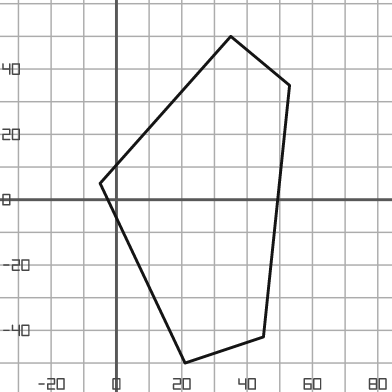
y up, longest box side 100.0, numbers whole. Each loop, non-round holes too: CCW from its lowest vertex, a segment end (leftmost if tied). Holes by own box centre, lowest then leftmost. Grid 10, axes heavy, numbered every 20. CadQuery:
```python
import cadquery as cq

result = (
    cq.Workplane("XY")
    .moveTo(21.0, -50.0)
    .lineTo(45.0, -42.0)
    .lineTo(53.0, 35.0)
    .lineTo(35.0, 50.0)
    .lineTo(-5.0, 5.0)
    .close()
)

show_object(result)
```